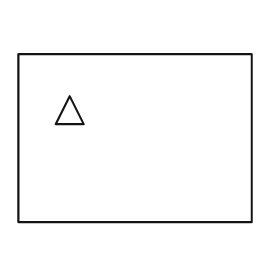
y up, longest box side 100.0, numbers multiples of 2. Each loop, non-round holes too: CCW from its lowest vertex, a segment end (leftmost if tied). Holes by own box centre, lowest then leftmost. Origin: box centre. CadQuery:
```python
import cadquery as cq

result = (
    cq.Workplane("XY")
    .moveTo(-50.0, -36.0)
    .lineTo(50.0, -36.0)
    .lineTo(50.0, 36.0)
    .lineTo(-50.0, 36.0)
    .close()
    .moveTo(-34.0, 6.0)
    .lineTo(-22.0, 6.0)
    .lineTo(-28.0, 18.0)
    .close()
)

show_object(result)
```